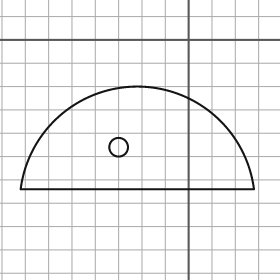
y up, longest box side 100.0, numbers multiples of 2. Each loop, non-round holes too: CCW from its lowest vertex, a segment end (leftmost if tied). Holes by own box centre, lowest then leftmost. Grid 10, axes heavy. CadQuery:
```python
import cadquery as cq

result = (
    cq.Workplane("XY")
    .moveTo(-72.0, -64.0)
    .lineTo(28.0, -64.0)
    .threePointArc((-22.0, -20.0), (-72.0, -64.0))
    .close()
    .moveTo(-30.0, -46.0)
    .circle(4.0)
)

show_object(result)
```